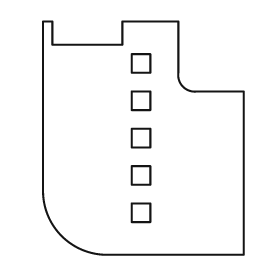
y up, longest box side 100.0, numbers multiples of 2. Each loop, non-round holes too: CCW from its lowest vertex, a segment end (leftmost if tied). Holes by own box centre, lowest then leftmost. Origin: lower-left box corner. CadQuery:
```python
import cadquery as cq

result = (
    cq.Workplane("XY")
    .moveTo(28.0, 0.0)
    .lineTo(86.0, 0.0)
    .lineTo(86.0, 70.0)
    .lineTo(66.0, 70.0)
    .threePointArc((60.0, 72.0), (58.0, 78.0))
    .lineTo(58.0, 100.0)
    .lineTo(34.0, 100.0)
    .lineTo(34.0, 90.0)
    .lineTo(4.0, 90.0)
    .lineTo(4.0, 100.0)
    .lineTo(0.0, 100.0)
    .lineTo(0.0, 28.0)
    .threePointArc((8.0, 8.0), (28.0, 0.0))
    .close()
    .moveTo(38.0, 14.0)
    .lineTo(46.0, 14.0)
    .lineTo(46.0, 22.0)
    .lineTo(38.0, 22.0)
    .close()
    .moveTo(38.0, 30.0)
    .lineTo(46.0, 30.0)
    .lineTo(46.0, 38.0)
    .lineTo(38.0, 38.0)
    .close()
    .moveTo(38.0, 46.0)
    .lineTo(46.0, 46.0)
    .lineTo(46.0, 54.0)
    .lineTo(38.0, 54.0)
    .close()
    .moveTo(38.0, 62.0)
    .lineTo(46.0, 62.0)
    .lineTo(46.0, 70.0)
    .lineTo(38.0, 70.0)
    .close()
    .moveTo(38.0, 78.0)
    .lineTo(46.0, 78.0)
    .lineTo(46.0, 86.0)
    .lineTo(38.0, 86.0)
    .close()
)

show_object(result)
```